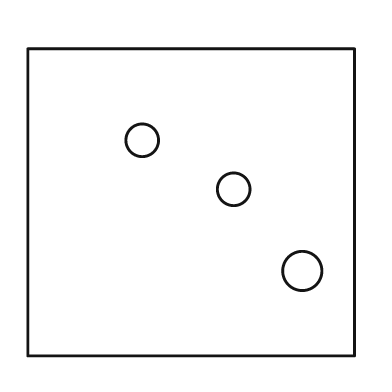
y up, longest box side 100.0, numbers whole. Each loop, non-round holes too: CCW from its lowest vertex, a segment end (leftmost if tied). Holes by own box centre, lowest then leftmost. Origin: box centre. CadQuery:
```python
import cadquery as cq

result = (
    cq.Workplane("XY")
    .moveTo(-50.0, -47.0)
    .lineTo(50.0, -47.0)
    .lineTo(50.0, 47.0)
    .lineTo(-50.0, 47.0)
    .close()
    .moveTo(34.0, -21.0)
    .circle(6.0)
    .moveTo(13.0, 4.0)
    .circle(5.0)
    .moveTo(-15.0, 19.0)
    .circle(5.0)
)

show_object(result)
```